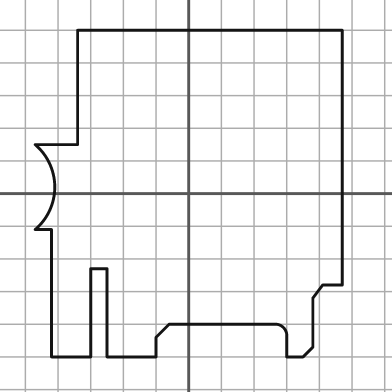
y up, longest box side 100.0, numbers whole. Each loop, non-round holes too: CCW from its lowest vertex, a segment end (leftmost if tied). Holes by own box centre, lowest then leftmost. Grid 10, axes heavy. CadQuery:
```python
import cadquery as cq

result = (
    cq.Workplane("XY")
    .moveTo(-42.0, -50.0)
    .lineTo(-30.0, -50.0)
    .lineTo(-30.0, -23.0)
    .lineTo(-25.0, -23.0)
    .lineTo(-25.0, -50.0)
    .lineTo(-10.0, -50.0)
    .lineTo(-10.0, -44.0)
    .lineTo(-6.0, -40.0)
    .lineTo(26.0, -40.0)
    .threePointArc((29.0, -41.0), (30.0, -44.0))
    .lineTo(30.0, -50.0)
    .lineTo(35.0, -50.0)
    .lineTo(38.0, -47.0)
    .lineTo(38.0, -32.0)
    .lineTo(41.0, -28.0)
    .lineTo(47.0, -28.0)
    .lineTo(47.0, 50.0)
    .lineTo(-34.0, 50.0)
    .lineTo(-34.0, 15.0)
    .lineTo(-47.0, 15.0)
    .threePointArc((-41.0, 2.0), (-47.0, -11.0))
    .lineTo(-42.0, -11.0)
    .close()
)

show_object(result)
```